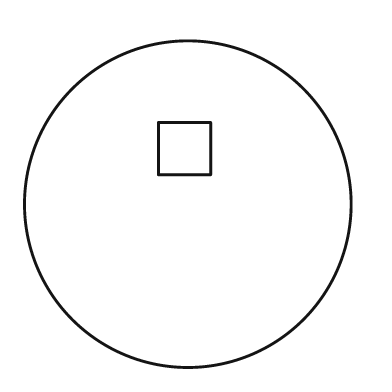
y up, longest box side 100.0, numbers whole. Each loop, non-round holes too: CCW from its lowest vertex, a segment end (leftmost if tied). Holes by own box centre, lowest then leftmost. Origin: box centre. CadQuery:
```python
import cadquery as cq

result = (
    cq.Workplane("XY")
    .moveTo(0.0, 0.0)
    .circle(50.0)
    .moveTo(-9.0, 9.0)
    .lineTo(7.0, 9.0)
    .lineTo(7.0, 25.0)
    .lineTo(-9.0, 25.0)
    .close()
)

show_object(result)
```